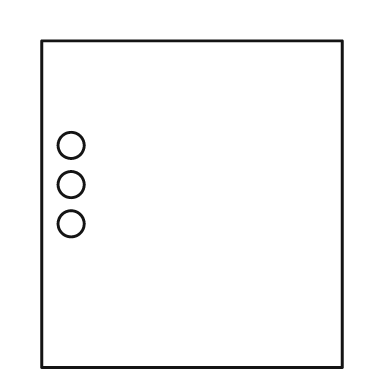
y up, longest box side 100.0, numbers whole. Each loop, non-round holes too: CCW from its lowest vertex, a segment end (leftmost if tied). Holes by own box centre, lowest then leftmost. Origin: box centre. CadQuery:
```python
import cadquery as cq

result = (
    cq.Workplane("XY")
    .moveTo(-46.0, -50.0)
    .lineTo(46.0, -50.0)
    .lineTo(46.0, 50.0)
    .lineTo(-46.0, 50.0)
    .close()
    .moveTo(-37.0, -6.0)
    .circle(4.0)
    .moveTo(-37.0, 6.0)
    .circle(4.0)
    .moveTo(-37.0, 18.0)
    .circle(4.0)
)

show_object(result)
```